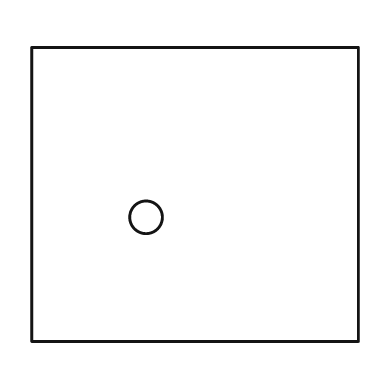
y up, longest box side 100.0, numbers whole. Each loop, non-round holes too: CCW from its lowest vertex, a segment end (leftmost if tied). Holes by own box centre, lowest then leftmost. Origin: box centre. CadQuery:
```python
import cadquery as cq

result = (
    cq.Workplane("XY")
    .moveTo(-50.0, -45.0)
    .lineTo(50.0, -45.0)
    .lineTo(50.0, 45.0)
    .lineTo(-50.0, 45.0)
    .close()
    .moveTo(-15.0, -7.0)
    .circle(5.0)
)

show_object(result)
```